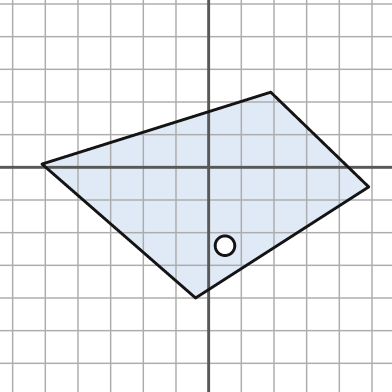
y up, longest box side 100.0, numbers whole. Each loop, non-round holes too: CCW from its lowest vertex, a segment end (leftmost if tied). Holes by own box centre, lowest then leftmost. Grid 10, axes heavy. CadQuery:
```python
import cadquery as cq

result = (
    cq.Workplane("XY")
    .moveTo(-4.0, -40.0)
    .lineTo(49.0, -6.0)
    .lineTo(19.0, 23.0)
    .lineTo(-51.0, 1.0)
    .close()
    .moveTo(5.0, -24.0)
    .circle(3.0)
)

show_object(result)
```